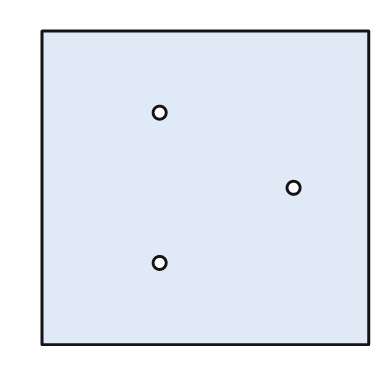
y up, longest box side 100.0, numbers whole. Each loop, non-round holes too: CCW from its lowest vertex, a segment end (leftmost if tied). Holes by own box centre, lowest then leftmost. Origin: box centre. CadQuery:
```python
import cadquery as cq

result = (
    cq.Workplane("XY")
    .moveTo(-50.0, -48.0)
    .lineTo(50.0, -48.0)
    .lineTo(50.0, 48.0)
    .lineTo(-50.0, 48.0)
    .close()
    .moveTo(-14.0, -23.0)
    .circle(2.0)
    .moveTo(27.0, 0.0)
    .circle(2.0)
    .moveTo(-14.0, 23.0)
    .circle(2.0)
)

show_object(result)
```